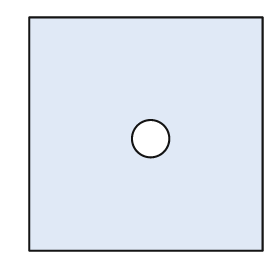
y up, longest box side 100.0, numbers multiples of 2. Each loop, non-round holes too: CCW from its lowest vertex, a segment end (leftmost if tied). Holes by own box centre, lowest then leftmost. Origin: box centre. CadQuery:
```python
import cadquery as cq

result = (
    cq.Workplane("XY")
    .moveTo(-50.0, -50.0)
    .lineTo(50.0, -50.0)
    .lineTo(50.0, 50.0)
    .lineTo(-50.0, 50.0)
    .close()
    .moveTo(2.0, -2.0)
    .circle(8.0)
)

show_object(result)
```